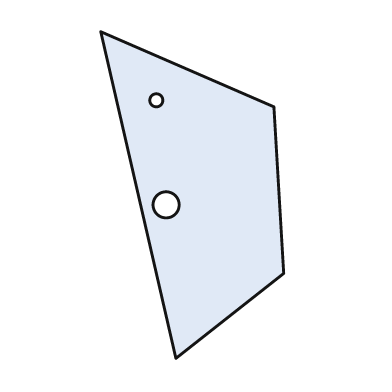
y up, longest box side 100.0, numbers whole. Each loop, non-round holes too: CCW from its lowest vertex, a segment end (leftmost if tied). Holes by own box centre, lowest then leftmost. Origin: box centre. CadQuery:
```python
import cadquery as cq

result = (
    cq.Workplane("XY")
    .moveTo(-5.0, -50.0)
    .lineTo(28.0, -24.0)
    .lineTo(25.0, 27.0)
    .lineTo(-28.0, 50.0)
    .close()
    .moveTo(-8.0, -3.0)
    .circle(4.0)
    .moveTo(-11.0, 29.0)
    .circle(2.0)
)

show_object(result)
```